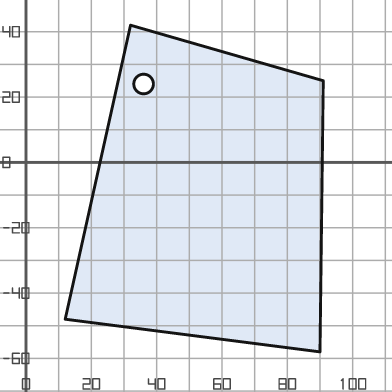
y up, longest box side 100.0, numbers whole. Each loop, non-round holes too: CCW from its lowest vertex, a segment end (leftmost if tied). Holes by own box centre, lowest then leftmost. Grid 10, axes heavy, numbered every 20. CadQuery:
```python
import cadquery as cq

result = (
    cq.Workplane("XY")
    .moveTo(90.0, -58.0)
    .lineTo(91.0, 25.0)
    .lineTo(32.0, 42.0)
    .lineTo(12.0, -48.0)
    .close()
    .moveTo(36.0, 24.0)
    .circle(3.0)
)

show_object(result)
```